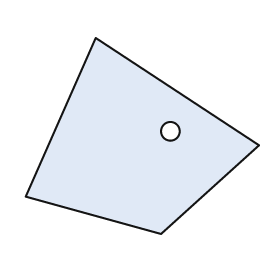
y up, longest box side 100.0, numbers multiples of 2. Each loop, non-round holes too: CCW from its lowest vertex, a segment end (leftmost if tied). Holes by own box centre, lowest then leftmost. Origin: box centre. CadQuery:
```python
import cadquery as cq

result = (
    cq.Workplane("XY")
    .moveTo(8.0, -42.0)
    .lineTo(50.0, -4.0)
    .lineTo(-20.0, 42.0)
    .lineTo(-50.0, -26.0)
    .close()
    .moveTo(12.0, 2.0)
    .circle(4.0)
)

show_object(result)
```